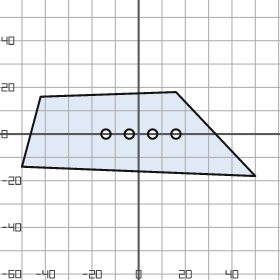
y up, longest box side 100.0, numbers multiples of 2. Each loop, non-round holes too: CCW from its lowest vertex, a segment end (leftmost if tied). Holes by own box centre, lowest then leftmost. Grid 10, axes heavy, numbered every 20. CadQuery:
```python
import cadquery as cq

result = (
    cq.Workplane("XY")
    .moveTo(50.0, -18.0)
    .lineTo(16.0, 18.0)
    .lineTo(-42.0, 16.0)
    .lineTo(-50.0, -14.0)
    .close()
    .moveTo(-14.0, 0.0)
    .circle(2.0)
    .moveTo(-4.0, 0.0)
    .circle(2.0)
    .moveTo(6.0, 0.0)
    .circle(2.0)
    .moveTo(16.0, 0.0)
    .circle(2.0)
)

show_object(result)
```